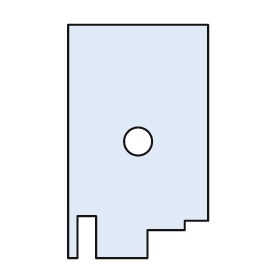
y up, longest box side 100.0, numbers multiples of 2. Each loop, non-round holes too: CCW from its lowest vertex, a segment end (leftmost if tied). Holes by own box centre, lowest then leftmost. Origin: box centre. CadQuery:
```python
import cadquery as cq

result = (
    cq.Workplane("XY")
    .moveTo(-30.0, -50.0)
    .lineTo(-26.0, -50.0)
    .lineTo(-26.0, -32.0)
    .lineTo(-18.0, -32.0)
    .lineTo(-18.0, -50.0)
    .lineTo(4.0, -50.0)
    .lineTo(4.0, -38.0)
    .lineTo(20.0, -38.0)
    .lineTo(20.0, -34.0)
    .lineTo(30.0, -34.0)
    .lineTo(30.0, 50.0)
    .lineTo(-30.0, 50.0)
    .close()
    .moveTo(0.0, 0.0)
    .circle(6.0)
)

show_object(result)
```